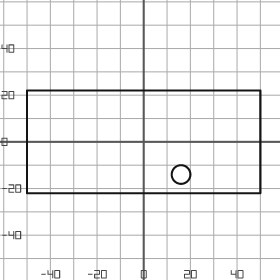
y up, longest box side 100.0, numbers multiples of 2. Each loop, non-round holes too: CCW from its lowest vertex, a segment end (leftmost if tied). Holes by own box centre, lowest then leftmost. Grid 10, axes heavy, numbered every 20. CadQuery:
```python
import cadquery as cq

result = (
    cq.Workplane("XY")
    .moveTo(-50.0, -22.0)
    .lineTo(50.0, -22.0)
    .lineTo(50.0, 22.0)
    .lineTo(-50.0, 22.0)
    .close()
    .moveTo(16.0, -14.0)
    .circle(4.0)
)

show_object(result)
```